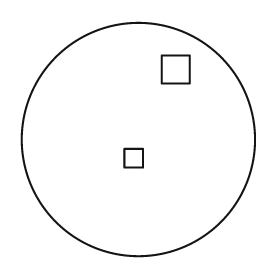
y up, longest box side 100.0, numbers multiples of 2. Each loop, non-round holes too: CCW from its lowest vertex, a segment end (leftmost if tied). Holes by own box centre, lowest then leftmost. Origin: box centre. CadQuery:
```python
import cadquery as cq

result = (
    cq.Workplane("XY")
    .moveTo(0.0, 0.0)
    .circle(50.0)
    .moveTo(-6.0, -12.0)
    .lineTo(2.0, -12.0)
    .lineTo(2.0, -4.0)
    .lineTo(-6.0, -4.0)
    .close()
    .moveTo(10.0, 24.0)
    .lineTo(22.0, 24.0)
    .lineTo(22.0, 36.0)
    .lineTo(10.0, 36.0)
    .close()
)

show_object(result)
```